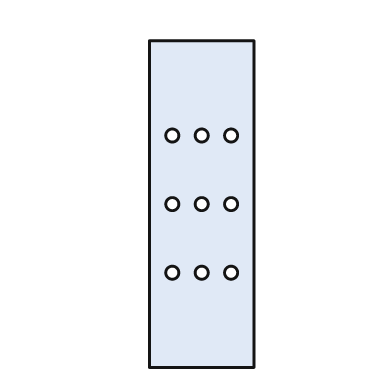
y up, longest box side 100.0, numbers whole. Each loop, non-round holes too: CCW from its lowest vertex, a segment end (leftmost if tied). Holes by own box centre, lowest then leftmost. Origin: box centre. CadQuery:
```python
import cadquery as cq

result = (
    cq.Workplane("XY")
    .moveTo(-16.0, -50.0)
    .lineTo(16.0, -50.0)
    .lineTo(16.0, 50.0)
    .lineTo(-16.0, 50.0)
    .close()
    .moveTo(-9.0, -21.0)
    .circle(2.0)
    .moveTo(0.0, -21.0)
    .circle(2.0)
    .moveTo(9.0, -21.0)
    .circle(2.0)
    .moveTo(-9.0, 0.0)
    .circle(2.0)
    .moveTo(0.0, 0.0)
    .circle(2.0)
    .moveTo(9.0, 0.0)
    .circle(2.0)
    .moveTo(-9.0, 21.0)
    .circle(2.0)
    .moveTo(0.0, 21.0)
    .circle(2.0)
    .moveTo(9.0, 21.0)
    .circle(2.0)
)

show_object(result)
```